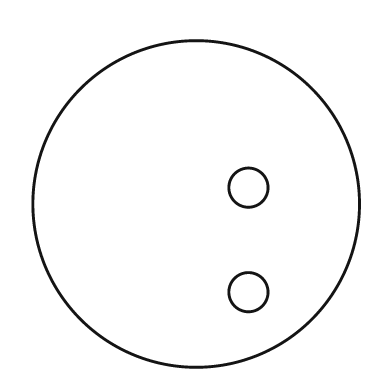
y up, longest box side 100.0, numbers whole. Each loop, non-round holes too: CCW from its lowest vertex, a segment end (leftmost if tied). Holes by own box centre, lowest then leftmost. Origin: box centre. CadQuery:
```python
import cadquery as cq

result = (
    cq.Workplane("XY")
    .moveTo(0.0, 0.0)
    .circle(50.0)
    .moveTo(16.0, -27.0)
    .circle(6.0)
    .moveTo(16.0, 5.0)
    .circle(6.0)
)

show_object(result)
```